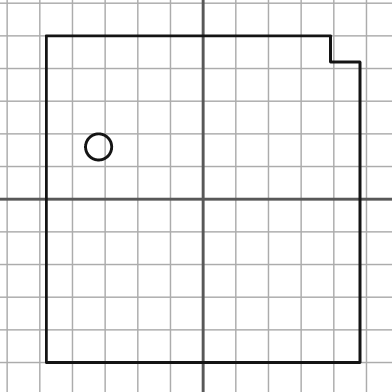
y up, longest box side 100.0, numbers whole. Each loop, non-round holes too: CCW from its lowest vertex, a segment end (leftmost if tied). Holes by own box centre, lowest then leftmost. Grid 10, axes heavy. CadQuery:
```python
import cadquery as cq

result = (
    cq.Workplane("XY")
    .moveTo(-48.0, -50.0)
    .lineTo(48.0, -50.0)
    .lineTo(48.0, 42.0)
    .lineTo(39.0, 42.0)
    .lineTo(39.0, 50.0)
    .lineTo(-48.0, 50.0)
    .close()
    .moveTo(-32.0, 16.0)
    .circle(4.0)
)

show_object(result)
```